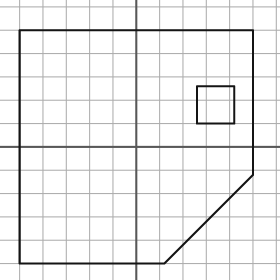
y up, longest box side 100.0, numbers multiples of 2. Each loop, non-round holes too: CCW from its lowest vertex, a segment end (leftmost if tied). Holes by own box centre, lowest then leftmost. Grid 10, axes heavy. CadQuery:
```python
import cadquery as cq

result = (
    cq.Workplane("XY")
    .moveTo(-50.0, -50.0)
    .lineTo(12.0, -50.0)
    .lineTo(50.0, -12.0)
    .lineTo(50.0, 50.0)
    .lineTo(-50.0, 50.0)
    .close()
    .moveTo(26.0, 10.0)
    .lineTo(42.0, 10.0)
    .lineTo(42.0, 26.0)
    .lineTo(26.0, 26.0)
    .close()
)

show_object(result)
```